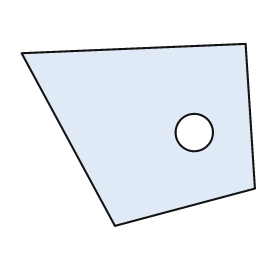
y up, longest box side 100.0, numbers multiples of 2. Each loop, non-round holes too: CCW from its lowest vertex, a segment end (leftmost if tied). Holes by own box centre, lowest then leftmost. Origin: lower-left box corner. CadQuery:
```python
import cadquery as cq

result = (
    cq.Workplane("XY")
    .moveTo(40.0, 0.0)
    .lineTo(100.0, 16.0)
    .lineTo(96.0, 78.0)
    .lineTo(0.0, 74.0)
    .close()
    .moveTo(74.0, 40.0)
    .circle(8.0)
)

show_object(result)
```